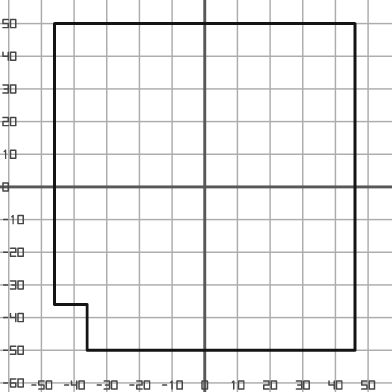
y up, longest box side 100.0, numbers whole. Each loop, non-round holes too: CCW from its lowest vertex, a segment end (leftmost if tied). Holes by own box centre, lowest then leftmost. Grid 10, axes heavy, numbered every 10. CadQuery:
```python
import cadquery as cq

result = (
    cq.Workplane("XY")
    .moveTo(-36.0, -50.0)
    .lineTo(46.0, -50.0)
    .lineTo(46.0, 50.0)
    .lineTo(-46.0, 50.0)
    .lineTo(-46.0, -36.0)
    .lineTo(-36.0, -36.0)
    .close()
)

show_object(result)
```